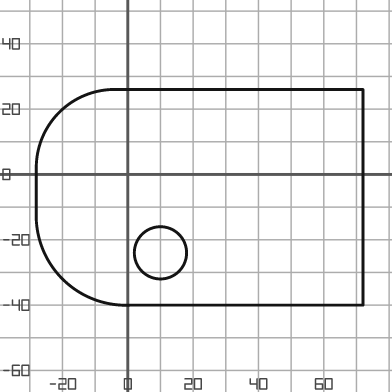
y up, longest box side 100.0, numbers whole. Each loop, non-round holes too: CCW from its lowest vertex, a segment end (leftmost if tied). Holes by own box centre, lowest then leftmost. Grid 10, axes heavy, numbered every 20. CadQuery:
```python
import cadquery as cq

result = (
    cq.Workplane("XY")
    .moveTo(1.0, -40.0)
    .lineTo(72.0, -40.0)
    .lineTo(72.0, 26.0)
    .lineTo(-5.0, 26.0)
    .threePointArc((-21.0, 19.0), (-28.0, 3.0))
    .lineTo(-28.0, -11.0)
    .threePointArc((-20.0, -32.0), (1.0, -40.0))
    .close()
    .moveTo(10.0, -24.0)
    .circle(8.0)
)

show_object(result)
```